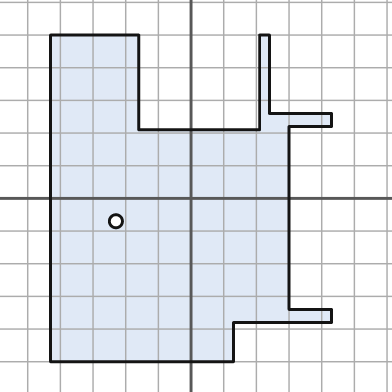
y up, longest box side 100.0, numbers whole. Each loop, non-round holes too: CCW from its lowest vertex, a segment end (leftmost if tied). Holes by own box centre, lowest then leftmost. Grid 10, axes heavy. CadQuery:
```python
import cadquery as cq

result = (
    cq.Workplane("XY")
    .moveTo(-43.0, -50.0)
    .lineTo(13.0, -50.0)
    .lineTo(13.0, -38.0)
    .lineTo(43.0, -38.0)
    .lineTo(43.0, -34.0)
    .lineTo(30.0, -34.0)
    .lineTo(30.0, 22.0)
    .lineTo(43.0, 22.0)
    .lineTo(43.0, 26.0)
    .lineTo(24.0, 26.0)
    .lineTo(24.0, 50.0)
    .lineTo(21.0, 50.0)
    .lineTo(21.0, 21.0)
    .lineTo(-16.0, 21.0)
    .lineTo(-16.0, 50.0)
    .lineTo(-43.0, 50.0)
    .close()
    .moveTo(-23.0, -7.0)
    .circle(2.0)
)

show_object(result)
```